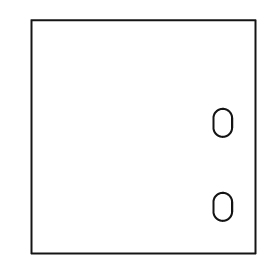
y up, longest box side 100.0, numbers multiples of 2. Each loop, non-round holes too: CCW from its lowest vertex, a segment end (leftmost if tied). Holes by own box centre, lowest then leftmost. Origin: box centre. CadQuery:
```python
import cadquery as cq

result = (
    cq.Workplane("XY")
    .moveTo(-48.0, -50.0)
    .lineTo(48.0, -50.0)
    .lineTo(48.0, 50.0)
    .lineTo(-48.0, 50.0)
    .close()
    .moveTo(30.0, -32.0)
    .threePointArc((34.0, -36.0), (38.0, -32.0))
    .lineTo(38.0, -28.0)
    .threePointArc((34.0, -24.0), (30.0, -28.0))
    .close()
    .moveTo(30.0, 4.0)
    .threePointArc((34.0, 0.0), (38.0, 4.0))
    .lineTo(38.0, 8.0)
    .threePointArc((34.0, 12.0), (30.0, 8.0))
    .close()
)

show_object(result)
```